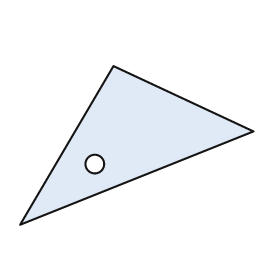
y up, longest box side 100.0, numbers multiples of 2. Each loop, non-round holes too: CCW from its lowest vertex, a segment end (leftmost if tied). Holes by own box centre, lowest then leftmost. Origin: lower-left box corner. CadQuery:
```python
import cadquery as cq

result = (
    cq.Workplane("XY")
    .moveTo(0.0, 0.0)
    .lineTo(100.0, 40.0)
    .lineTo(40.0, 68.0)
    .close()
    .moveTo(32.0, 26.0)
    .circle(4.0)
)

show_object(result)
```